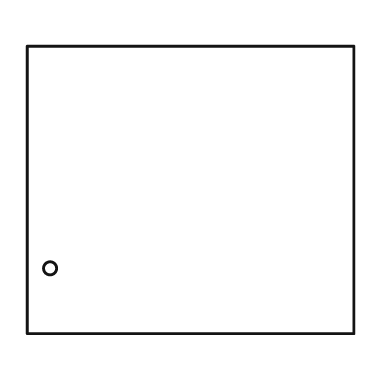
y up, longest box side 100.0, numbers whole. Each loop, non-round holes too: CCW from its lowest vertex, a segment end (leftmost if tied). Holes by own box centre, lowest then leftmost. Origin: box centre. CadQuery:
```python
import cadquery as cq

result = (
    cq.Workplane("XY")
    .moveTo(-50.0, -44.0)
    .lineTo(50.0, -44.0)
    .lineTo(50.0, 44.0)
    .lineTo(-50.0, 44.0)
    .close()
    .moveTo(-43.0, -24.0)
    .circle(2.0)
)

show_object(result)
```